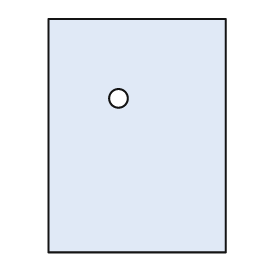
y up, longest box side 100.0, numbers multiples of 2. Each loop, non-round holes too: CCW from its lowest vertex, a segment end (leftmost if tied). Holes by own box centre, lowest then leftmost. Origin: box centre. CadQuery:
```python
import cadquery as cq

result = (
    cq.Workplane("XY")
    .moveTo(-38.0, -50.0)
    .lineTo(38.0, -50.0)
    .lineTo(38.0, 50.0)
    .lineTo(-38.0, 50.0)
    .close()
    .moveTo(-8.0, 16.0)
    .circle(4.0)
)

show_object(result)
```